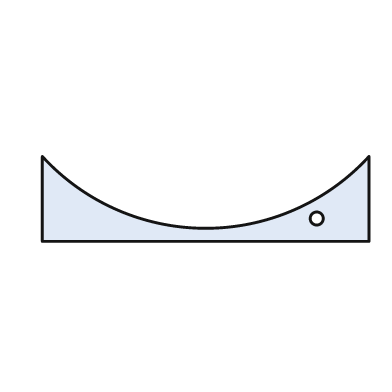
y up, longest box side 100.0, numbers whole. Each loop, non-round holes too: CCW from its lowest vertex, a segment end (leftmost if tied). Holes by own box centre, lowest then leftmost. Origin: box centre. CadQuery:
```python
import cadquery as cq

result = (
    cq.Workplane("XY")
    .moveTo(-50.0, -13.0)
    .lineTo(50.0, -13.0)
    .lineTo(50.0, 13.0)
    .threePointArc((0.0, -9.0), (-50.0, 13.0))
    .close()
    .moveTo(34.0, -6.0)
    .circle(2.0)
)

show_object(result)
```